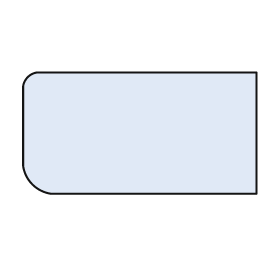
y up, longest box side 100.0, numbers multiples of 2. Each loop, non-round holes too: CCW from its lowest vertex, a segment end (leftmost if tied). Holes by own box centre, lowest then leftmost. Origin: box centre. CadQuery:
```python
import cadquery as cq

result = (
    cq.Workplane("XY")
    .moveTo(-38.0, -26.0)
    .lineTo(50.0, -26.0)
    .lineTo(50.0, 26.0)
    .lineTo(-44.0, 26.0)
    .threePointArc((-48.0, 24.0), (-50.0, 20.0))
    .lineTo(-50.0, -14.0)
    .threePointArc((-46.0, -22.0), (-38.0, -26.0))
    .close()
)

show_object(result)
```